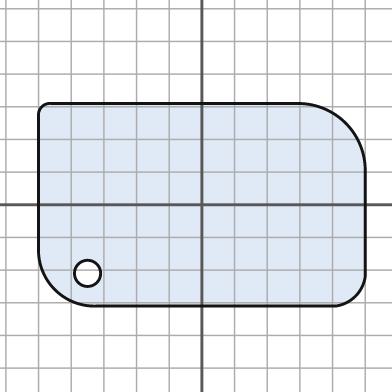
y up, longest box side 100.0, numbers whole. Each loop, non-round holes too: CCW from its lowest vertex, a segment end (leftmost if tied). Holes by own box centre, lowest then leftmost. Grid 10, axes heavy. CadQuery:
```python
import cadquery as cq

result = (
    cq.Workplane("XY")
    .moveTo(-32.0, -31.0)
    .lineTo(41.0, -31.0)
    .threePointArc((47.0, -28.0), (50.0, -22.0))
    .lineTo(50.0, 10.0)
    .threePointArc((44.0, 25.0), (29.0, 31.0))
    .lineTo(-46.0, 31.0)
    .threePointArc((-49.0, 30.0), (-50.0, 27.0))
    .lineTo(-50.0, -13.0)
    .threePointArc((-45.0, -26.0), (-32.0, -31.0))
    .close()
    .moveTo(-35.0, -21.0)
    .circle(4.0)
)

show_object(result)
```